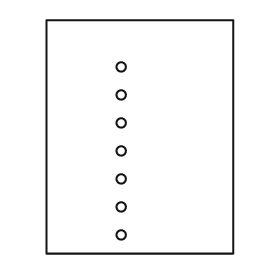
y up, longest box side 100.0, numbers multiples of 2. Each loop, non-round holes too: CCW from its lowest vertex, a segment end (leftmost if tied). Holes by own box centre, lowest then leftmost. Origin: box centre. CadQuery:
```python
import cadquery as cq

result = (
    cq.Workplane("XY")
    .moveTo(-40.0, -50.0)
    .lineTo(40.0, -50.0)
    .lineTo(40.0, 50.0)
    .lineTo(-40.0, 50.0)
    .close()
    .moveTo(-8.0, -42.0)
    .circle(2.0)
    .moveTo(-8.0, -30.0)
    .circle(2.0)
    .moveTo(-8.0, -18.0)
    .circle(2.0)
    .moveTo(-8.0, -6.0)
    .circle(2.0)
    .moveTo(-8.0, 6.0)
    .circle(2.0)
    .moveTo(-8.0, 18.0)
    .circle(2.0)
    .moveTo(-8.0, 30.0)
    .circle(2.0)
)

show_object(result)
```